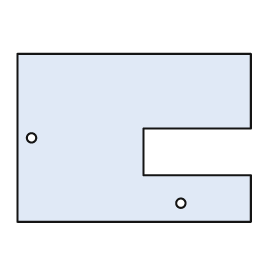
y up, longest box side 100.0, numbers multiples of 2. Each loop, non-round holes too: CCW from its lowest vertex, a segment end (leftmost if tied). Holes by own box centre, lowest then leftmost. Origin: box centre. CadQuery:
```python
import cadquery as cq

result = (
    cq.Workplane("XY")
    .moveTo(-50.0, -36.0)
    .lineTo(50.0, -36.0)
    .lineTo(50.0, -16.0)
    .lineTo(4.0, -16.0)
    .lineTo(4.0, 4.0)
    .lineTo(50.0, 4.0)
    .lineTo(50.0, 36.0)
    .lineTo(-50.0, 36.0)
    .close()
    .moveTo(20.0, -28.0)
    .circle(2.0)
    .moveTo(-44.0, 0.0)
    .circle(2.0)
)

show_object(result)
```